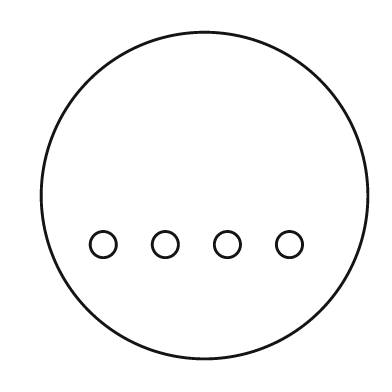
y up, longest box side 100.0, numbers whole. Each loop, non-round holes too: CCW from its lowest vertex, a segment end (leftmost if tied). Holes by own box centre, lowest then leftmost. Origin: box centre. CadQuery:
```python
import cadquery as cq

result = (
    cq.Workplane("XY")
    .moveTo(0.0, 0.0)
    .circle(50.0)
    .moveTo(-31.0, -15.0)
    .circle(4.0)
    .moveTo(-12.0, -15.0)
    .circle(4.0)
    .moveTo(7.0, -15.0)
    .circle(4.0)
    .moveTo(26.0, -15.0)
    .circle(4.0)
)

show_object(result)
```